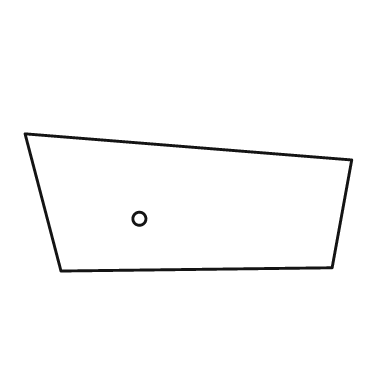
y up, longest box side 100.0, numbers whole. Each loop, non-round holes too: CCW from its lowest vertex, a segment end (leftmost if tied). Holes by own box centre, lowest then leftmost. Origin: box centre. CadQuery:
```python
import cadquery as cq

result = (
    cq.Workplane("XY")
    .moveTo(-39.0, -21.0)
    .lineTo(44.0, -20.0)
    .lineTo(50.0, 13.0)
    .lineTo(-50.0, 21.0)
    .close()
    .moveTo(-15.0, -5.0)
    .circle(2.0)
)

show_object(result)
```